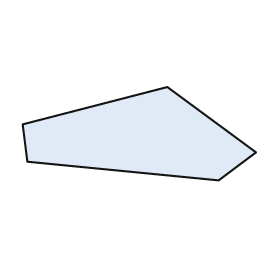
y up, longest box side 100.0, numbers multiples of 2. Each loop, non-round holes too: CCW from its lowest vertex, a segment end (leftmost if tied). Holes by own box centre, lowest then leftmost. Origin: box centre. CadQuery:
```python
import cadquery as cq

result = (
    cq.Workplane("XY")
    .moveTo(34.0, -20.0)
    .lineTo(50.0, -8.0)
    .lineTo(12.0, 20.0)
    .lineTo(-50.0, 4.0)
    .lineTo(-48.0, -12.0)
    .close()
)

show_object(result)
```